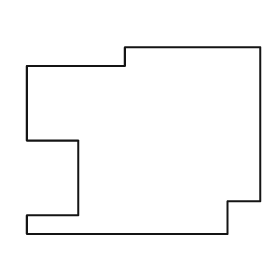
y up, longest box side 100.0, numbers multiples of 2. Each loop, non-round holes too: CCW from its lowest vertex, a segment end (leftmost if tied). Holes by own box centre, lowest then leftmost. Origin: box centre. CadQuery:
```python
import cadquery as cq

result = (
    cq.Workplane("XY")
    .moveTo(-50.0, -40.0)
    .lineTo(36.0, -40.0)
    .lineTo(36.0, -26.0)
    .lineTo(50.0, -26.0)
    .lineTo(50.0, 40.0)
    .lineTo(-8.0, 40.0)
    .lineTo(-8.0, 32.0)
    .lineTo(-50.0, 32.0)
    .lineTo(-50.0, 0.0)
    .lineTo(-28.0, 0.0)
    .lineTo(-28.0, -32.0)
    .lineTo(-50.0, -32.0)
    .close()
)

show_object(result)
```